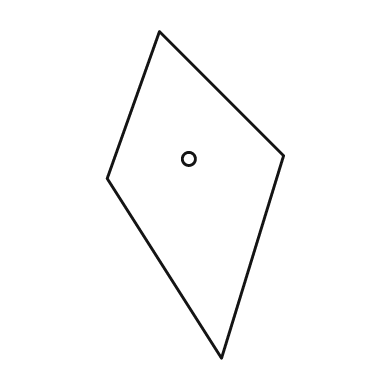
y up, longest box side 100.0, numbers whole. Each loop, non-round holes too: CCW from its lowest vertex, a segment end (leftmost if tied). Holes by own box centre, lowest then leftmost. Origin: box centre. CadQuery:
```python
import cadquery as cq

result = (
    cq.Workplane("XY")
    .moveTo(8.0, -50.0)
    .lineTo(27.0, 12.0)
    .lineTo(-11.0, 50.0)
    .lineTo(-27.0, 5.0)
    .close()
    .moveTo(-2.0, 11.0)
    .circle(2.0)
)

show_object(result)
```